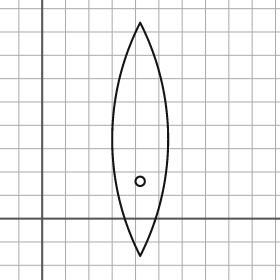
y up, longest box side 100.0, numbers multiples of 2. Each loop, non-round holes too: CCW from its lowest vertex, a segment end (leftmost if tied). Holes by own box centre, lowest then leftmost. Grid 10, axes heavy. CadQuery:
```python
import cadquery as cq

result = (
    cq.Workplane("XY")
    .moveTo(42.0, -16.0)
    .threePointArc((54.0, 34.0), (42.0, 84.0))
    .threePointArc((30.0, 34.0), (42.0, -16.0))
    .close()
    .moveTo(42.0, 16.0)
    .circle(2.0)
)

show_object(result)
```